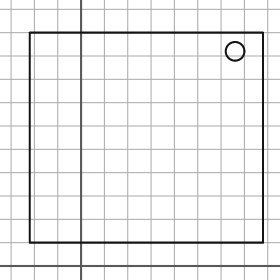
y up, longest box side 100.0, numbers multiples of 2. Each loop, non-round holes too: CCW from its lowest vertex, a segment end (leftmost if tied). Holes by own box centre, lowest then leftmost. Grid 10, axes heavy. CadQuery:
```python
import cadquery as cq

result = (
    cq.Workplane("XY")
    .moveTo(-22.0, 10.0)
    .lineTo(78.0, 10.0)
    .lineTo(78.0, 100.0)
    .lineTo(-22.0, 100.0)
    .close()
    .moveTo(66.0, 92.0)
    .circle(4.0)
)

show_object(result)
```